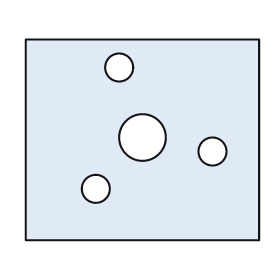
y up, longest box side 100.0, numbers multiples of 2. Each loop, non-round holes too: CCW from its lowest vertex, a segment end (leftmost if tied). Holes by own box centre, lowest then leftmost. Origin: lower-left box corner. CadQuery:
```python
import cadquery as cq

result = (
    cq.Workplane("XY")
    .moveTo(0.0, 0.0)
    .lineTo(100.0, 0.0)
    .lineTo(100.0, 86.0)
    .lineTo(0.0, 86.0)
    .close()
    .moveTo(30.0, 22.0)
    .circle(6.0)
    .moveTo(80.0, 38.0)
    .circle(6.0)
    .moveTo(50.0, 44.0)
    .circle(10.0)
    .moveTo(40.0, 74.0)
    .circle(6.0)
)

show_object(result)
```